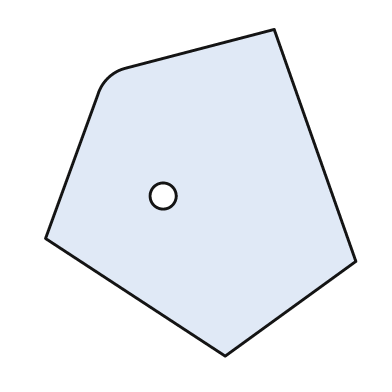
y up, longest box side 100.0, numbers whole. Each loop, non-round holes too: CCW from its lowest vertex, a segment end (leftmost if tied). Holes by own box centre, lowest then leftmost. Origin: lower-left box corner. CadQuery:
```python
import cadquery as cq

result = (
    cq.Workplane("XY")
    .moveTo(55.0, 0.0)
    .lineTo(95.0, 29.0)
    .lineTo(70.0, 100.0)
    .lineTo(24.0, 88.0)
    .threePointArc((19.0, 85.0), (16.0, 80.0))
    .lineTo(0.0, 36.0)
    .close()
    .moveTo(36.0, 49.0)
    .circle(4.0)
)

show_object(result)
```